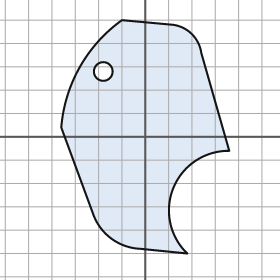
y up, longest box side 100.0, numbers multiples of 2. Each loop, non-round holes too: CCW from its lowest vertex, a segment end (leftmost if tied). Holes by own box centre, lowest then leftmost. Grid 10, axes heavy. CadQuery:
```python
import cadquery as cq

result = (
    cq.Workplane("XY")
    .moveTo(18.0, -50.0)
    .threePointArc((12.0, -22.0), (36.0, -6.0))
    .lineTo(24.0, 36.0)
    .threePointArc((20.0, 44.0), (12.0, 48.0))
    .lineTo(-10.0, 50.0)
    .threePointArc((-28.0, 30.0), (-36.0, 4.0))
    .lineTo(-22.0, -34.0)
    .threePointArc((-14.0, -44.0), (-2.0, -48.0))
    .close()
    .moveTo(-18.0, 28.0)
    .circle(4.0)
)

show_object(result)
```